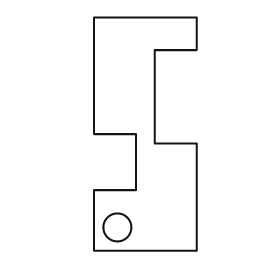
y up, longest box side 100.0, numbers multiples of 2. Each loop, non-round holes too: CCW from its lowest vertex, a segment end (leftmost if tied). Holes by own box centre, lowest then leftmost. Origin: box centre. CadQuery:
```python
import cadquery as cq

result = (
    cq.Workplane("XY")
    .moveTo(-22.0, -50.0)
    .lineTo(22.0, -50.0)
    .lineTo(22.0, -4.0)
    .lineTo(4.0, -4.0)
    .lineTo(4.0, 36.0)
    .lineTo(22.0, 36.0)
    .lineTo(22.0, 50.0)
    .lineTo(-22.0, 50.0)
    .lineTo(-22.0, 0.0)
    .lineTo(-4.0, 0.0)
    .lineTo(-4.0, -24.0)
    .lineTo(-22.0, -24.0)
    .close()
    .moveTo(-12.0, -40.0)
    .circle(6.0)
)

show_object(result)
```